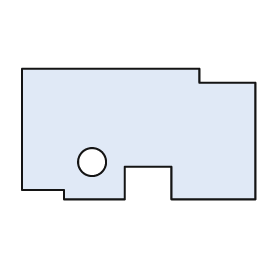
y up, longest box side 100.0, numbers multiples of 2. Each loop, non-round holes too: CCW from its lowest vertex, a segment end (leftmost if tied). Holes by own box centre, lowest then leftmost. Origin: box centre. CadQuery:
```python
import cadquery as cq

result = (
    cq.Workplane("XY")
    .moveTo(-32.0, -28.0)
    .lineTo(-6.0, -28.0)
    .lineTo(-6.0, -14.0)
    .lineTo(14.0, -14.0)
    .lineTo(14.0, -28.0)
    .lineTo(50.0, -28.0)
    .lineTo(50.0, 22.0)
    .lineTo(26.0, 22.0)
    .lineTo(26.0, 28.0)
    .lineTo(-50.0, 28.0)
    .lineTo(-50.0, -24.0)
    .lineTo(-32.0, -24.0)
    .close()
    .moveTo(-20.0, -12.0)
    .circle(6.0)
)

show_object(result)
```